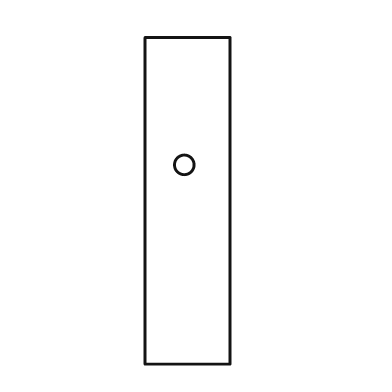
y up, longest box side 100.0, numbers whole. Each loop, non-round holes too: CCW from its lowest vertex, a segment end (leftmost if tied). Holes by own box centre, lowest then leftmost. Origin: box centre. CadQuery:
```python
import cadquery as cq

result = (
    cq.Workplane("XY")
    .moveTo(-13.0, -50.0)
    .lineTo(13.0, -50.0)
    .lineTo(13.0, 50.0)
    .lineTo(-13.0, 50.0)
    .close()
    .moveTo(-1.0, 11.0)
    .circle(3.0)
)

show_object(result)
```